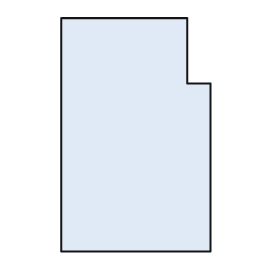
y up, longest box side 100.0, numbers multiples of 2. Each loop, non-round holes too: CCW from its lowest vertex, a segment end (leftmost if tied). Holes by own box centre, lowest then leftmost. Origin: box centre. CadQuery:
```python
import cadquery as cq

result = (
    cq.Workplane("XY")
    .moveTo(-32.0, -50.0)
    .lineTo(32.0, -50.0)
    .lineTo(32.0, 22.0)
    .lineTo(22.0, 22.0)
    .lineTo(22.0, 50.0)
    .lineTo(-32.0, 50.0)
    .close()
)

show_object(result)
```